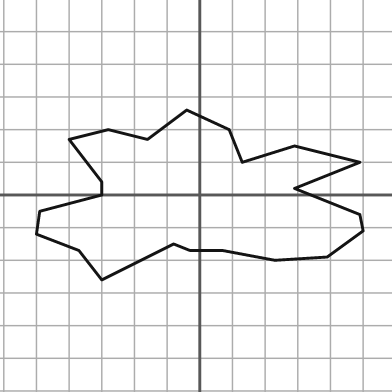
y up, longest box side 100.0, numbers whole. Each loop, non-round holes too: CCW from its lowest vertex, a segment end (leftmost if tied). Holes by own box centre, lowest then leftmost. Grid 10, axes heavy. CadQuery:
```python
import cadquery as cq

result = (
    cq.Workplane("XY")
    .moveTo(-30.0, -26.0)
    .lineTo(-8.0, -15.0)
    .lineTo(-3.0, -17.0)
    .lineTo(7.0, -17.0)
    .lineTo(23.0, -20.0)
    .lineTo(39.0, -19.0)
    .lineTo(50.0, -11.0)
    .lineTo(49.0, -6.0)
    .lineTo(29.0, 2.0)
    .lineTo(49.0, 10.0)
    .lineTo(29.0, 15.0)
    .lineTo(13.0, 10.0)
    .lineTo(9.0, 20.0)
    .lineTo(-4.0, 26.0)
    .lineTo(-16.0, 17.0)
    .lineTo(-28.0, 20.0)
    .lineTo(-40.0, 17.0)
    .lineTo(-30.0, 4.0)
    .lineTo(-30.0, 0.0)
    .lineTo(-49.0, -5.0)
    .lineTo(-50.0, -12.0)
    .lineTo(-37.0, -17.0)
    .close()
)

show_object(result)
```